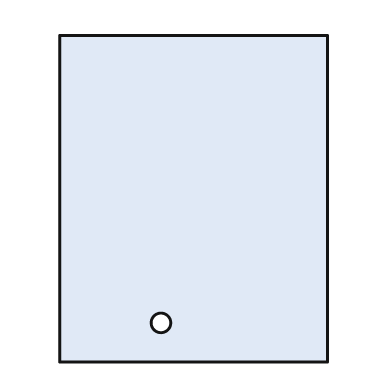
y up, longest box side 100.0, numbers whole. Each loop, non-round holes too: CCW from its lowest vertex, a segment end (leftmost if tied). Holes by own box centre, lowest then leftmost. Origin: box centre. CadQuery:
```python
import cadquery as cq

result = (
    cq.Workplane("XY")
    .moveTo(-41.0, -50.0)
    .lineTo(41.0, -50.0)
    .lineTo(41.0, 50.0)
    .lineTo(-41.0, 50.0)
    .close()
    .moveTo(-10.0, -38.0)
    .circle(3.0)
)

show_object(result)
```